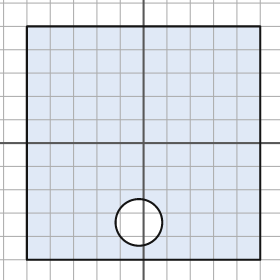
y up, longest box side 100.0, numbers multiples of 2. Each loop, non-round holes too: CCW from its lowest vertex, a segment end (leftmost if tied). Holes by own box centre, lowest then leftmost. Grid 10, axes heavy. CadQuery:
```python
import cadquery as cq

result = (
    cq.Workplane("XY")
    .moveTo(-50.0, -50.0)
    .lineTo(50.0, -50.0)
    .lineTo(50.0, 50.0)
    .lineTo(-50.0, 50.0)
    .close()
    .moveTo(-2.0, -34.0)
    .circle(10.0)
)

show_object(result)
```